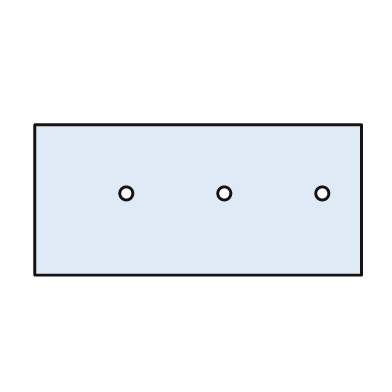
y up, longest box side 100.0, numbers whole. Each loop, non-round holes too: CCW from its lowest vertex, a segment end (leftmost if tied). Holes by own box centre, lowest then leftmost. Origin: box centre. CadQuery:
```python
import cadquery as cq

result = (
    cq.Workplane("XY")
    .moveTo(-50.0, -23.0)
    .lineTo(50.0, -23.0)
    .lineTo(50.0, 23.0)
    .lineTo(-50.0, 23.0)
    .close()
    .moveTo(-22.0, 2.0)
    .circle(2.0)
    .moveTo(8.0, 2.0)
    .circle(2.0)
    .moveTo(38.0, 2.0)
    .circle(2.0)
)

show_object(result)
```